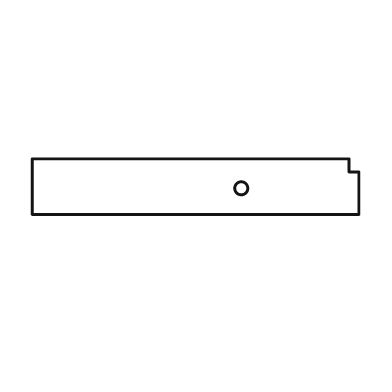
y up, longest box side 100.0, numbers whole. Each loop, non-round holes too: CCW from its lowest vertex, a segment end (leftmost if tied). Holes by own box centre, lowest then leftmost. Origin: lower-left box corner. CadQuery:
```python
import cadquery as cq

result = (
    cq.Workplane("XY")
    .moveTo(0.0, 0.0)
    .lineTo(100.0, 0.0)
    .lineTo(100.0, 13.0)
    .lineTo(97.0, 13.0)
    .lineTo(97.0, 17.0)
    .lineTo(0.0, 17.0)
    .close()
    .moveTo(64.0, 8.0)
    .circle(2.0)
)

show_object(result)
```